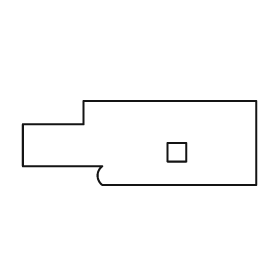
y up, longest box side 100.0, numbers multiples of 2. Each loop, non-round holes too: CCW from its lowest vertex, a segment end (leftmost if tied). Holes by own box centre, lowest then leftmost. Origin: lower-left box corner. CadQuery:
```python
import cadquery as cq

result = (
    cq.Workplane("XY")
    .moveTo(34.0, 0.0)
    .lineTo(100.0, 0.0)
    .lineTo(100.0, 36.0)
    .lineTo(26.0, 36.0)
    .lineTo(26.0, 26.0)
    .lineTo(0.0, 26.0)
    .lineTo(0.0, 8.0)
    .lineTo(34.0, 8.0)
    .threePointArc((32.0, 4.0), (34.0, 0.0))
    .close()
    .moveTo(62.0, 10.0)
    .lineTo(70.0, 10.0)
    .lineTo(70.0, 18.0)
    .lineTo(62.0, 18.0)
    .close()
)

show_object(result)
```